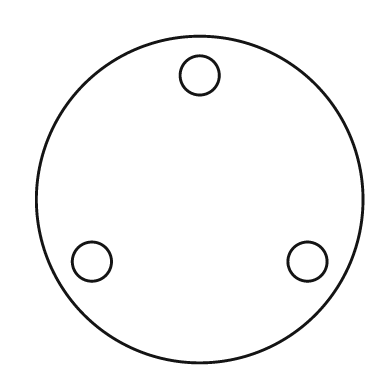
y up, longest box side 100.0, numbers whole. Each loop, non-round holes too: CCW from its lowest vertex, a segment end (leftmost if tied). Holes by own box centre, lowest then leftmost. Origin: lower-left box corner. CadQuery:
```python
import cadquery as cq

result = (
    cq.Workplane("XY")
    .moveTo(50.0, 50.0)
    .circle(50.0)
    .moveTo(17.0, 31.0)
    .circle(6.0)
    .moveTo(83.0, 31.0)
    .circle(6.0)
    .moveTo(50.0, 88.0)
    .circle(6.0)
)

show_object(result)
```